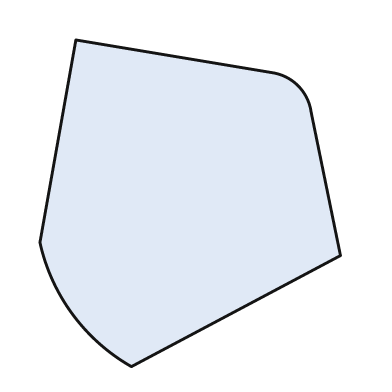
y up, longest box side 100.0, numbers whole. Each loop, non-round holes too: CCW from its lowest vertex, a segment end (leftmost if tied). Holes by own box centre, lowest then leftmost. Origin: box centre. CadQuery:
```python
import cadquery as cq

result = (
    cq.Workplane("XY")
    .moveTo(-18.0, -50.0)
    .lineTo(46.0, -16.0)
    .lineTo(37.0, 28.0)
    .threePointArc((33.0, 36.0), (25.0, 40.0))
    .lineTo(-35.0, 50.0)
    .lineTo(-46.0, -12.0)
    .threePointArc((-36.0, -34.0), (-18.0, -50.0))
    .close()
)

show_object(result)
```